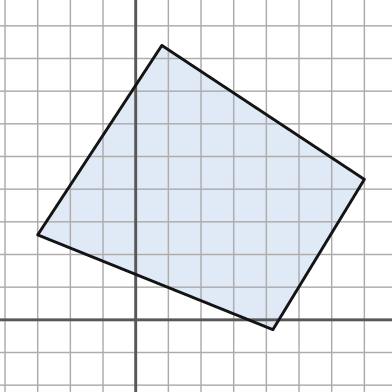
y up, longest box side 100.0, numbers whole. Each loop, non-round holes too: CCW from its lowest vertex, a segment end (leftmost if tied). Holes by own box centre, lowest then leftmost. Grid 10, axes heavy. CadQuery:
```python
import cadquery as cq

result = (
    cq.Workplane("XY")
    .moveTo(42.0, -3.0)
    .lineTo(70.0, 43.0)
    .lineTo(8.0, 84.0)
    .lineTo(-30.0, 26.0)
    .close()
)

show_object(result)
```